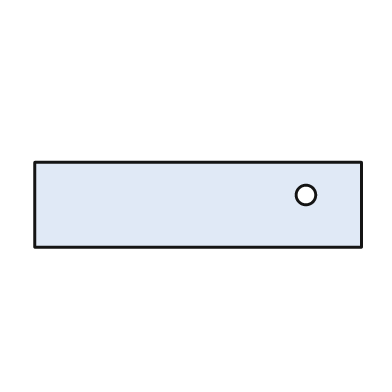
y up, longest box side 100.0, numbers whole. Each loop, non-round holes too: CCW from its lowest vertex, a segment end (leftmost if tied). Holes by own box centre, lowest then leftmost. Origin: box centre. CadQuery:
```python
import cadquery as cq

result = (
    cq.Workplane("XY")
    .moveTo(-50.0, -13.0)
    .lineTo(50.0, -13.0)
    .lineTo(50.0, 13.0)
    .lineTo(-50.0, 13.0)
    .close()
    .moveTo(33.0, 3.0)
    .circle(3.0)
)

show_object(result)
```